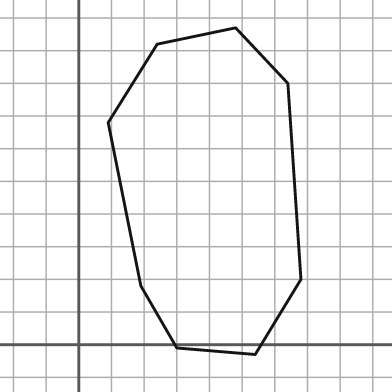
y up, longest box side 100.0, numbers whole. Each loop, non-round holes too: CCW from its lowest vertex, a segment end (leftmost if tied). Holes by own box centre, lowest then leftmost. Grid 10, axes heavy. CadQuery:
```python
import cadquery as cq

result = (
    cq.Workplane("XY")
    .moveTo(54.0, -3.0)
    .lineTo(68.0, 20.0)
    .lineTo(64.0, 80.0)
    .lineTo(48.0, 97.0)
    .lineTo(24.0, 92.0)
    .lineTo(9.0, 68.0)
    .lineTo(19.0, 18.0)
    .lineTo(30.0, -1.0)
    .close()
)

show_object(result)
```